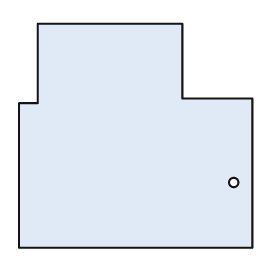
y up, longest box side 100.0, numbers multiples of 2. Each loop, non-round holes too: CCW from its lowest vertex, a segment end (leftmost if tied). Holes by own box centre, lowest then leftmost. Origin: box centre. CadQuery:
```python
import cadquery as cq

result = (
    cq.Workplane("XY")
    .moveTo(-50.0, -48.0)
    .lineTo(50.0, -48.0)
    .lineTo(50.0, 16.0)
    .lineTo(20.0, 16.0)
    .lineTo(20.0, 48.0)
    .lineTo(-42.0, 48.0)
    .lineTo(-42.0, 14.0)
    .lineTo(-50.0, 14.0)
    .close()
    .moveTo(42.0, -20.0)
    .circle(2.0)
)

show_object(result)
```